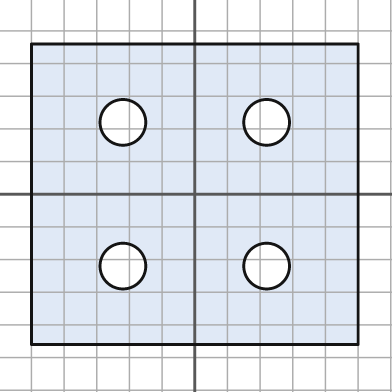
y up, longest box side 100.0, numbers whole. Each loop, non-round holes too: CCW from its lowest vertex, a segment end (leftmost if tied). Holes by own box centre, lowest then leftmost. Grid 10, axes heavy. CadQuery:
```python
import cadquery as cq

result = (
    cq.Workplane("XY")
    .moveTo(-50.0, -46.0)
    .lineTo(50.0, -46.0)
    .lineTo(50.0, 46.0)
    .lineTo(-50.0, 46.0)
    .close()
    .moveTo(-22.0, -22.0)
    .circle(7.0)
    .moveTo(22.0, -22.0)
    .circle(7.0)
    .moveTo(-22.0, 22.0)
    .circle(7.0)
    .moveTo(22.0, 22.0)
    .circle(7.0)
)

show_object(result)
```